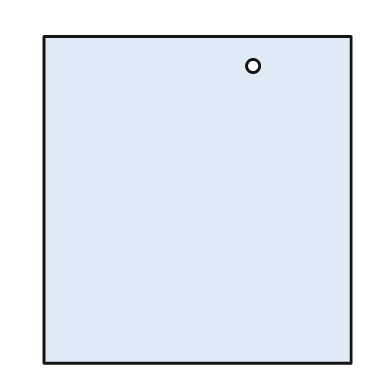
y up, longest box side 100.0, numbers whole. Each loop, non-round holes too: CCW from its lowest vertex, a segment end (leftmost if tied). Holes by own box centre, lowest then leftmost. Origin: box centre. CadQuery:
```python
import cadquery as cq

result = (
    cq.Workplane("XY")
    .moveTo(-47.0, -50.0)
    .lineTo(47.0, -50.0)
    .lineTo(47.0, 50.0)
    .lineTo(-47.0, 50.0)
    .close()
    .moveTo(17.0, 41.0)
    .circle(2.0)
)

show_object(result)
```